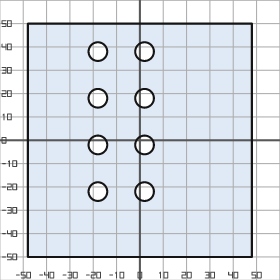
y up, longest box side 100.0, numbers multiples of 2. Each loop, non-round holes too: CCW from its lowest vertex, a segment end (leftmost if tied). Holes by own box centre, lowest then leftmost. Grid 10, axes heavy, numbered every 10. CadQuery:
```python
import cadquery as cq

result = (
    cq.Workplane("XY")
    .moveTo(-48.0, -50.0)
    .lineTo(48.0, -50.0)
    .lineTo(48.0, 50.0)
    .lineTo(-48.0, 50.0)
    .close()
    .moveTo(-18.0, -22.0)
    .circle(4.0)
    .moveTo(2.0, -22.0)
    .circle(4.0)
    .moveTo(-18.0, -2.0)
    .circle(4.0)
    .moveTo(2.0, -2.0)
    .circle(4.0)
    .moveTo(-18.0, 18.0)
    .circle(4.0)
    .moveTo(2.0, 18.0)
    .circle(4.0)
    .moveTo(-18.0, 38.0)
    .circle(4.0)
    .moveTo(2.0, 38.0)
    .circle(4.0)
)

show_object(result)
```